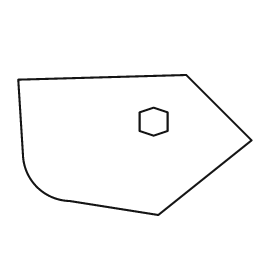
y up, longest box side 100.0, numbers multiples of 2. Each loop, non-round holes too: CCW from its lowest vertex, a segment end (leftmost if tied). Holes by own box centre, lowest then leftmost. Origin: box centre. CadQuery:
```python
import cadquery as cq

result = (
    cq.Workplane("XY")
    .moveTo(10.0, -30.0)
    .lineTo(50.0, 2.0)
    .lineTo(22.0, 30.0)
    .lineTo(-50.0, 28.0)
    .lineTo(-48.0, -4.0)
    .threePointArc((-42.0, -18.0), (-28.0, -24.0))
    .close()
    .moveTo(8.0, 4.0)
    .lineTo(14.0, 6.0)
    .lineTo(14.0, 14.0)
    .lineTo(8.0, 16.0)
    .lineTo(2.0, 14.0)
    .lineTo(2.0, 6.0)
    .close()
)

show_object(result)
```